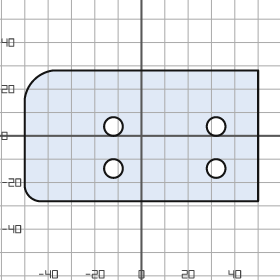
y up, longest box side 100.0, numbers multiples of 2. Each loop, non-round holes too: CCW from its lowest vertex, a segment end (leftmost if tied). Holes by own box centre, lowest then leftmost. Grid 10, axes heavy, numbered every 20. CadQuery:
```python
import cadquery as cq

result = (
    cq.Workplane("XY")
    .moveTo(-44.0, -28.0)
    .lineTo(50.0, -28.0)
    .lineTo(50.0, 28.0)
    .lineTo(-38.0, 28.0)
    .threePointArc((-46.0, 24.0), (-50.0, 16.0))
    .lineTo(-50.0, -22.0)
    .threePointArc((-48.0, -26.0), (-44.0, -28.0))
    .close()
    .moveTo(-12.0, -14.0)
    .circle(4.0)
    .moveTo(32.0, -14.0)
    .circle(4.0)
    .moveTo(-12.0, 4.0)
    .circle(4.0)
    .moveTo(32.0, 4.0)
    .circle(4.0)
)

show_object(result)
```